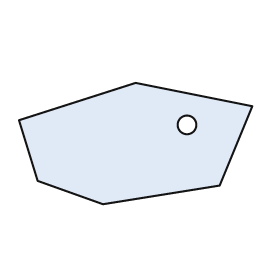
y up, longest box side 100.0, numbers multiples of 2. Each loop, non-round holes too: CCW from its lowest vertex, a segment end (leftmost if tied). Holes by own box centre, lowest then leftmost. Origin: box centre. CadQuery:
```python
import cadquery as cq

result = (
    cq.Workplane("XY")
    .moveTo(-14.0, -26.0)
    .lineTo(36.0, -18.0)
    .lineTo(50.0, 16.0)
    .lineTo(0.0, 26.0)
    .lineTo(-50.0, 10.0)
    .lineTo(-42.0, -16.0)
    .close()
    .moveTo(22.0, 8.0)
    .circle(4.0)
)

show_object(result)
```